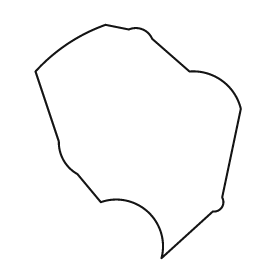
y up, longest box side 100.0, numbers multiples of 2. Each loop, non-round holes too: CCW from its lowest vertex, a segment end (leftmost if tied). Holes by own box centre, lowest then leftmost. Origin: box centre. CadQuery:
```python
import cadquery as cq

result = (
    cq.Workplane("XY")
    .moveTo(10.0, -50.0)
    .lineTo(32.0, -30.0)
    .threePointArc((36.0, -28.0), (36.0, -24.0))
    .lineTo(44.0, 14.0)
    .threePointArc((36.0, 26.0), (22.0, 30.0))
    .lineTo(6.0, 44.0)
    .threePointArc((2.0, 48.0), (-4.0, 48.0))
    .lineTo(-14.0, 50.0)
    .threePointArc((-30.0, 42.0), (-44.0, 30.0))
    .lineTo(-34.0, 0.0)
    .threePointArc((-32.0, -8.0), (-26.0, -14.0))
    .lineTo(-16.0, -26.0)
    .threePointArc((4.0, -30.0), (10.0, -50.0))
    .close()
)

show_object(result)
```